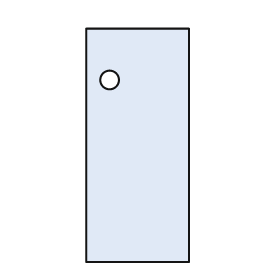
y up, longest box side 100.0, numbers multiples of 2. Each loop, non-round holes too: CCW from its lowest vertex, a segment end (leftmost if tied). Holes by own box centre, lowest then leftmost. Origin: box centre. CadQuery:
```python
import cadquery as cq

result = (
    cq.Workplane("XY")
    .moveTo(-22.0, -50.0)
    .lineTo(22.0, -50.0)
    .lineTo(22.0, 50.0)
    .lineTo(-22.0, 50.0)
    .close()
    .moveTo(-12.0, 28.0)
    .circle(4.0)
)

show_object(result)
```